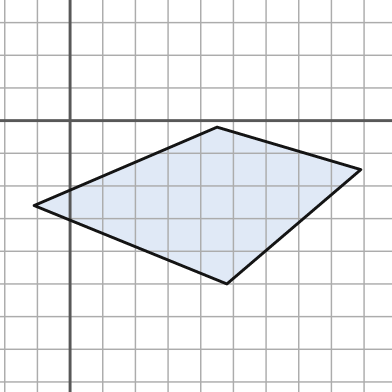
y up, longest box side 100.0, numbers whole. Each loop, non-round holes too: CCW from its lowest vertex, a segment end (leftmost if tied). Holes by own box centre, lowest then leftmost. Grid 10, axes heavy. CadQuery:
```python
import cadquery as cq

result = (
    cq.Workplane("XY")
    .moveTo(48.0, -50.0)
    .lineTo(89.0, -15.0)
    .lineTo(45.0, -2.0)
    .lineTo(-11.0, -26.0)
    .close()
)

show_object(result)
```